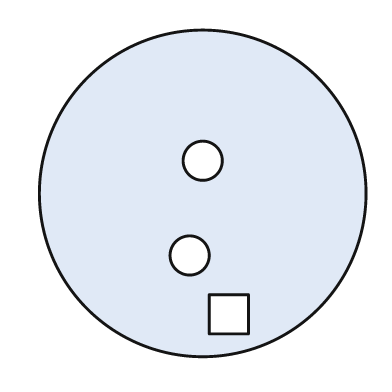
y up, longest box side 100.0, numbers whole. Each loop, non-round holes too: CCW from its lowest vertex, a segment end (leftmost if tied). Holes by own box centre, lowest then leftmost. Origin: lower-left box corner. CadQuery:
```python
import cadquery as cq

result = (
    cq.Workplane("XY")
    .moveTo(50.0, 50.0)
    .circle(50.0)
    .moveTo(52.0, 7.0)
    .lineTo(64.0, 7.0)
    .lineTo(64.0, 19.0)
    .lineTo(52.0, 19.0)
    .close()
    .moveTo(46.0, 31.0)
    .circle(6.0)
    .moveTo(50.0, 60.0)
    .circle(6.0)
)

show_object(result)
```